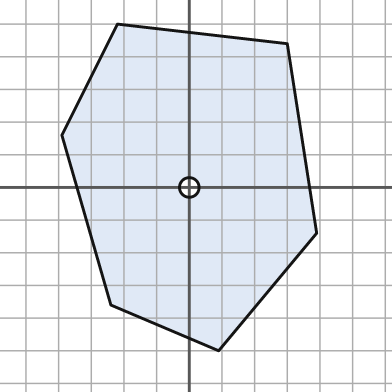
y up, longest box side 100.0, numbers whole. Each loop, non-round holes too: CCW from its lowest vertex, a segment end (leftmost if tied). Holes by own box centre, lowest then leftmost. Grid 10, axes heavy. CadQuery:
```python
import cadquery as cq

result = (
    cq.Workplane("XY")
    .moveTo(9.0, -50.0)
    .lineTo(39.0, -14.0)
    .lineTo(30.0, 44.0)
    .lineTo(-22.0, 50.0)
    .lineTo(-39.0, 16.0)
    .lineTo(-24.0, -36.0)
    .close()
    .moveTo(0.0, 0.0)
    .circle(3.0)
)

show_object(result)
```